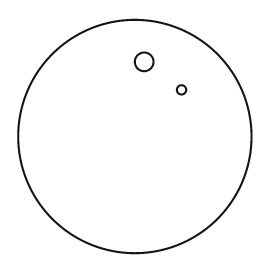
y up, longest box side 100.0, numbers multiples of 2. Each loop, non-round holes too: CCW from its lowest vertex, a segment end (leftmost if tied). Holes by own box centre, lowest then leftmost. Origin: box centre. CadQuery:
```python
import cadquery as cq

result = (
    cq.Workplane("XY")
    .moveTo(0.0, 0.0)
    .circle(50.0)
    .moveTo(20.0, 20.0)
    .circle(2.0)
    .moveTo(4.0, 32.0)
    .circle(4.0)
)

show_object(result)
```